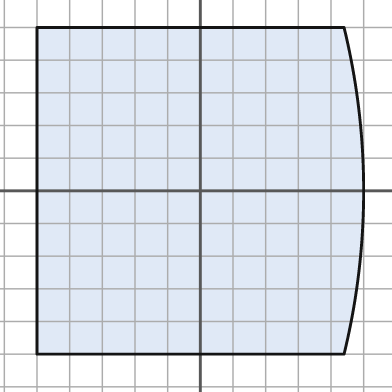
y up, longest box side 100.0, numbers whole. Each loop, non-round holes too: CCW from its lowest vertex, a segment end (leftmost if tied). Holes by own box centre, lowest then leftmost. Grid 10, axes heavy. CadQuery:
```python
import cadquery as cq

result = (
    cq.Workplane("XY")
    .moveTo(-50.0, -50.0)
    .lineTo(44.0, -50.0)
    .threePointArc((50.0, 0.0), (44.0, 50.0))
    .lineTo(-50.0, 50.0)
    .close()
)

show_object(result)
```